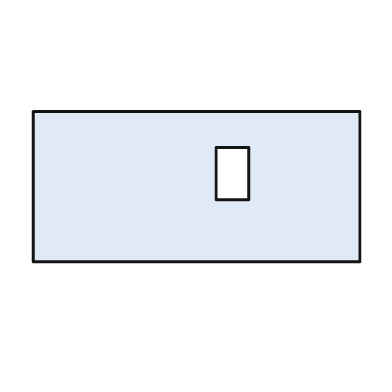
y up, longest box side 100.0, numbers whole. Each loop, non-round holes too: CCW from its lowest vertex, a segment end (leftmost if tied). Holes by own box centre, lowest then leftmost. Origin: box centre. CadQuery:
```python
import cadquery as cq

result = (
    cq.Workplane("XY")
    .moveTo(-50.0, -23.0)
    .lineTo(50.0, -23.0)
    .lineTo(50.0, 23.0)
    .lineTo(-50.0, 23.0)
    .close()
    .moveTo(6.0, -4.0)
    .lineTo(16.0, -4.0)
    .lineTo(16.0, 12.0)
    .lineTo(6.0, 12.0)
    .close()
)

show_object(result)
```